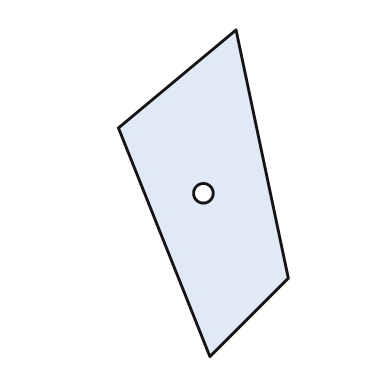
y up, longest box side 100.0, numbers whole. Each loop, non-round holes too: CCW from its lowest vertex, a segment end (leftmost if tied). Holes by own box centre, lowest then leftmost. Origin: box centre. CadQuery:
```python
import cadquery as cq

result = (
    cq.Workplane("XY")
    .moveTo(2.0, -50.0)
    .lineTo(26.0, -26.0)
    .lineTo(10.0, 50.0)
    .lineTo(-26.0, 20.0)
    .close()
    .moveTo(0.0, 0.0)
    .circle(3.0)
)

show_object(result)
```